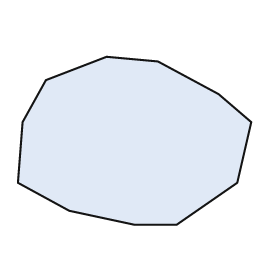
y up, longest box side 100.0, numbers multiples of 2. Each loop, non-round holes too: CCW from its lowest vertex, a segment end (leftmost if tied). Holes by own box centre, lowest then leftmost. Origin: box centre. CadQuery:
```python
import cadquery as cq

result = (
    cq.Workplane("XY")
    .moveTo(0.0, -36.0)
    .lineTo(18.0, -36.0)
    .lineTo(44.0, -18.0)
    .lineTo(50.0, 8.0)
    .lineTo(36.0, 20.0)
    .lineTo(10.0, 34.0)
    .lineTo(-12.0, 36.0)
    .lineTo(-38.0, 26.0)
    .lineTo(-48.0, 8.0)
    .lineTo(-50.0, -18.0)
    .lineTo(-28.0, -30.0)
    .close()
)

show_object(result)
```